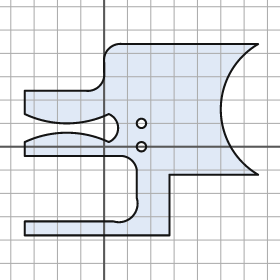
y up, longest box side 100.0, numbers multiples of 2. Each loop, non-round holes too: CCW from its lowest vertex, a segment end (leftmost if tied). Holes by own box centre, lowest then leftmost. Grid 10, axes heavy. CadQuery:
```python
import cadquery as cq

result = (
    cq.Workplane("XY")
    .moveTo(-34.0, -38.0)
    .lineTo(28.0, -38.0)
    .lineTo(28.0, -12.0)
    .lineTo(66.0, -12.0)
    .threePointArc((50.0, 16.0), (66.0, 44.0))
    .lineTo(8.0, 44.0)
    .threePointArc((2.0, 42.0), (0.0, 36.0))
    .lineTo(0.0, 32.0)
    .threePointArc((-2.0, 26.0), (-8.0, 24.0))
    .lineTo(-34.0, 24.0)
    .lineTo(-34.0, 14.0)
    .threePointArc((-16.0, 10.0), (2.0, 14.0))
    .threePointArc((6.0, 8.0), (2.0, 2.0))
    .threePointArc((-16.0, 6.0), (-34.0, 2.0))
    .lineTo(-34.0, -4.0)
    .lineTo(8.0, -4.0)
    .threePointArc((12.0, -6.0), (14.0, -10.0))
    .lineTo(14.0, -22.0)
    .threePointArc((12.0, -30.0), (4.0, -32.0))
    .lineTo(-34.0, -32.0)
    .close()
    .moveTo(16.0, 0.0)
    .circle(2.0)
    .moveTo(16.0, 10.0)
    .circle(2.0)
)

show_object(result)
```